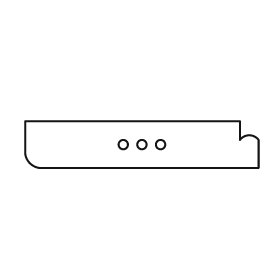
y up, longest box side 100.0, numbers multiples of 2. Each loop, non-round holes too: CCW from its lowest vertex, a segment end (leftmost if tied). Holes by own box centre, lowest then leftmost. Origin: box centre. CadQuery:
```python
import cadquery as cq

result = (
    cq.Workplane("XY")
    .moveTo(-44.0, -10.0)
    .lineTo(50.0, -10.0)
    .lineTo(50.0, 2.0)
    .threePointArc((46.0, 4.0), (42.0, 2.0))
    .lineTo(42.0, 10.0)
    .lineTo(-50.0, 10.0)
    .lineTo(-50.0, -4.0)
    .threePointArc((-48.0, -8.0), (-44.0, -10.0))
    .close()
    .moveTo(-8.0, 0.0)
    .circle(2.0)
    .moveTo(0.0, 0.0)
    .circle(2.0)
    .moveTo(8.0, 0.0)
    .circle(2.0)
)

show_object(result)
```